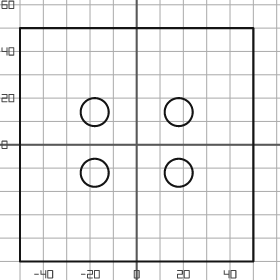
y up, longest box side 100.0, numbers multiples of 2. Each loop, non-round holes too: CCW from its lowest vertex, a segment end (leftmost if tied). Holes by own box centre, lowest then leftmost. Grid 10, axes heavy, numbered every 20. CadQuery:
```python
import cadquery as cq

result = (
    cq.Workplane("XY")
    .moveTo(-50.0, -50.0)
    .lineTo(50.0, -50.0)
    .lineTo(50.0, 50.0)
    .lineTo(-50.0, 50.0)
    .close()
    .moveTo(-18.0, -12.0)
    .circle(6.0)
    .moveTo(18.0, -12.0)
    .circle(6.0)
    .moveTo(-18.0, 14.0)
    .circle(6.0)
    .moveTo(18.0, 14.0)
    .circle(6.0)
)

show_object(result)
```